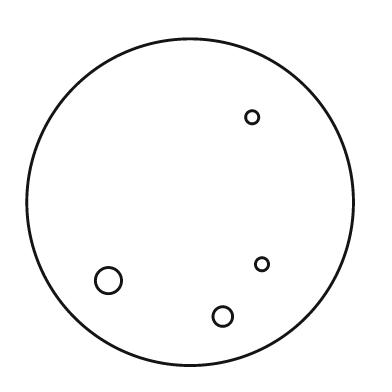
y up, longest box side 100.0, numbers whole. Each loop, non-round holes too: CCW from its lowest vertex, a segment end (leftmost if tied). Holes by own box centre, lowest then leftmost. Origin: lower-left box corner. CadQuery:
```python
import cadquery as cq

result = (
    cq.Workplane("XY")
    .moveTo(50.0, 50.0)
    .circle(50.0)
    .moveTo(60.0, 15.0)
    .circle(3.0)
    .moveTo(25.0, 26.0)
    .circle(4.0)
    .moveTo(72.0, 31.0)
    .circle(2.0)
    .moveTo(69.0, 76.0)
    .circle(2.0)
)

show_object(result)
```